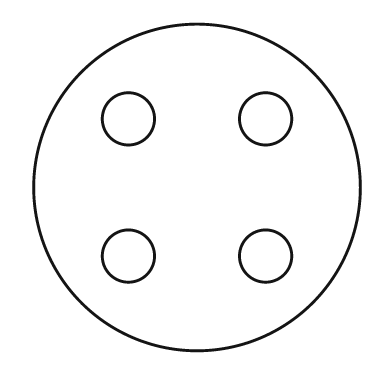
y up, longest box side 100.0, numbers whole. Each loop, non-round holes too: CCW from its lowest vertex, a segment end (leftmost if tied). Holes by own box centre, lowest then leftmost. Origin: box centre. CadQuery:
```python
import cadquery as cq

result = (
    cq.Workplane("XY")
    .moveTo(0.0, 0.0)
    .circle(50.0)
    .moveTo(-21.0, -21.0)
    .circle(8.0)
    .moveTo(21.0, -21.0)
    .circle(8.0)
    .moveTo(-21.0, 21.0)
    .circle(8.0)
    .moveTo(21.0, 21.0)
    .circle(8.0)
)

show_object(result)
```